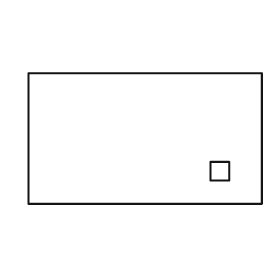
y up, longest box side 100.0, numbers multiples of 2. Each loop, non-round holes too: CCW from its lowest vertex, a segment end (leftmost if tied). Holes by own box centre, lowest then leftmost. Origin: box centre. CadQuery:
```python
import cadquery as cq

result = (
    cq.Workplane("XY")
    .moveTo(-50.0, -28.0)
    .lineTo(50.0, -28.0)
    .lineTo(50.0, 28.0)
    .lineTo(-50.0, 28.0)
    .close()
    .moveTo(28.0, -18.0)
    .lineTo(36.0, -18.0)
    .lineTo(36.0, -10.0)
    .lineTo(28.0, -10.0)
    .close()
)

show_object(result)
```